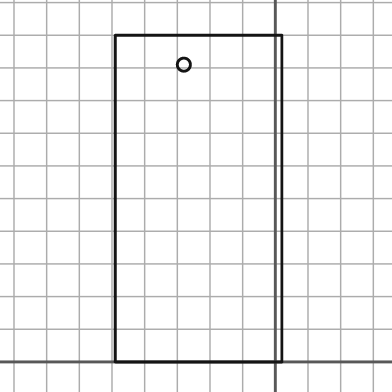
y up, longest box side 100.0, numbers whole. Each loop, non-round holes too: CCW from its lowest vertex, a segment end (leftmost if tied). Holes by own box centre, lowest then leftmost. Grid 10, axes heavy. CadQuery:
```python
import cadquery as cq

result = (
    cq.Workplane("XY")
    .moveTo(-49.0, 0.0)
    .lineTo(2.0, 0.0)
    .lineTo(2.0, 100.0)
    .lineTo(-49.0, 100.0)
    .close()
    .moveTo(-28.0, 91.0)
    .circle(2.0)
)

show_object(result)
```